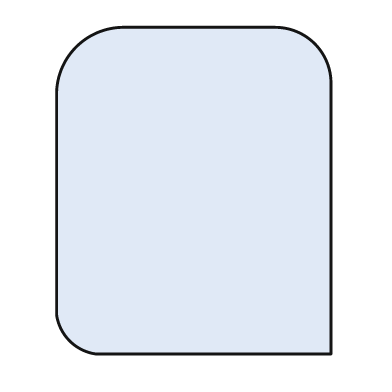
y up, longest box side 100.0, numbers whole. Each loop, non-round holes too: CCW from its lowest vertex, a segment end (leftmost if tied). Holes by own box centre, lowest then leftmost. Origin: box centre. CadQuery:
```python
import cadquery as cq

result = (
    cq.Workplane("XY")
    .moveTo(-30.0, -50.0)
    .lineTo(42.0, -50.0)
    .lineTo(42.0, 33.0)
    .threePointArc((37.0, 45.0), (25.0, 50.0))
    .lineTo(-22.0, 50.0)
    .threePointArc((-36.0, 44.0), (-42.0, 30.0))
    .lineTo(-42.0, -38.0)
    .threePointArc((-38.0, -46.0), (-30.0, -50.0))
    .close()
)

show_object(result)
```